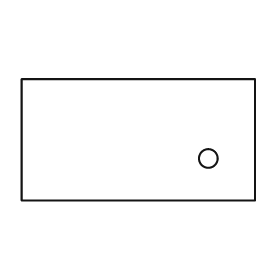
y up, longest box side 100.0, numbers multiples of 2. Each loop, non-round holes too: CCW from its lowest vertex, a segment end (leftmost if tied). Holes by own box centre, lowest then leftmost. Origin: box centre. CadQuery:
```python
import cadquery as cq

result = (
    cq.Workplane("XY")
    .moveTo(-50.0, -26.0)
    .lineTo(50.0, -26.0)
    .lineTo(50.0, 26.0)
    .lineTo(-50.0, 26.0)
    .close()
    .moveTo(30.0, -8.0)
    .circle(4.0)
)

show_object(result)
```